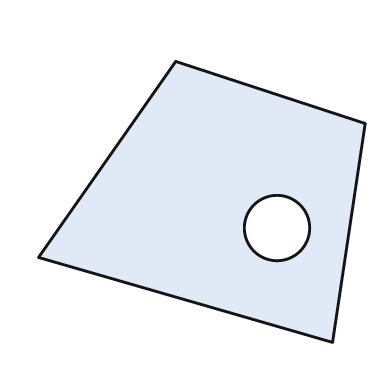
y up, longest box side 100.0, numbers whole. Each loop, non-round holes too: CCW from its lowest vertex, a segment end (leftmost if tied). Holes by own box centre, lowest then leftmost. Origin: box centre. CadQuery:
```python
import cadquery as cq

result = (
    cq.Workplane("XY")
    .moveTo(40.0, -43.0)
    .lineTo(50.0, 24.0)
    .lineTo(-8.0, 43.0)
    .lineTo(-50.0, -17.0)
    .close()
    .moveTo(23.0, -8.0)
    .circle(10.0)
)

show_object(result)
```